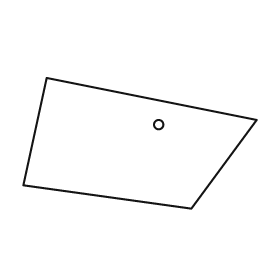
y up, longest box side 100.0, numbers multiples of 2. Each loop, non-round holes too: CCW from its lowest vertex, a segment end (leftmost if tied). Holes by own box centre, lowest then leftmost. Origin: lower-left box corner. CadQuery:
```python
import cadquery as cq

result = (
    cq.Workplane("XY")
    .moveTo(72.0, 0.0)
    .lineTo(100.0, 38.0)
    .lineTo(10.0, 56.0)
    .lineTo(0.0, 10.0)
    .close()
    .moveTo(58.0, 36.0)
    .circle(2.0)
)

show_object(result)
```